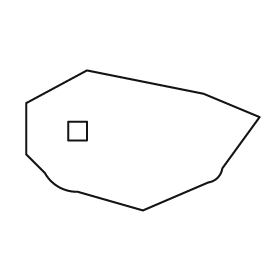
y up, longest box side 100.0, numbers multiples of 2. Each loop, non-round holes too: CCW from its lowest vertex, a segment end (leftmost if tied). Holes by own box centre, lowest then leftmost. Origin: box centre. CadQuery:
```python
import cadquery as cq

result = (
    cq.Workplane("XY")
    .moveTo(0.0, -30.0)
    .lineTo(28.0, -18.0)
    .threePointArc((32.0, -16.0), (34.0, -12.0))
    .lineTo(50.0, 10.0)
    .lineTo(26.0, 20.0)
    .lineTo(-24.0, 30.0)
    .lineTo(-50.0, 16.0)
    .lineTo(-50.0, -6.0)
    .lineTo(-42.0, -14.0)
    .threePointArc((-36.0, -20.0), (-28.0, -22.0))
    .close()
    .moveTo(-32.0, 0.0)
    .lineTo(-24.0, 0.0)
    .lineTo(-24.0, 8.0)
    .lineTo(-32.0, 8.0)
    .close()
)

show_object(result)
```